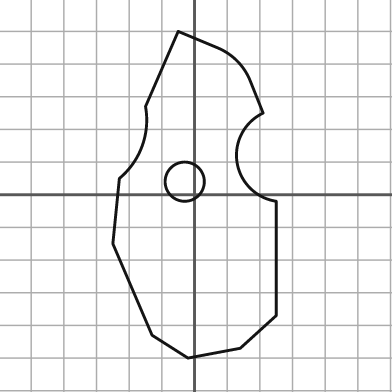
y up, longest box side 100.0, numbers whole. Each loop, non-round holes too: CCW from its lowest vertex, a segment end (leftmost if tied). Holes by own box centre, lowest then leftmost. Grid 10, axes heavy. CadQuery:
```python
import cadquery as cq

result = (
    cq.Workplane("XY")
    .moveTo(-2.0, -50.0)
    .lineTo(14.0, -47.0)
    .lineTo(25.0, -37.0)
    .lineTo(25.0, -2.0)
    .threePointArc((13.0, 10.0), (21.0, 25.0))
    .lineTo(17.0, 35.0)
    .threePointArc((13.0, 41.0), (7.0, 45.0))
    .lineTo(-5.0, 50.0)
    .lineTo(-15.0, 27.0)
    .threePointArc((-16.0, 15.0), (-23.0, 5.0))
    .lineTo(-25.0, -15.0)
    .lineTo(-13.0, -43.0)
    .close()
    .moveTo(-3.0, 4.0)
    .circle(6.0)
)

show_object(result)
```